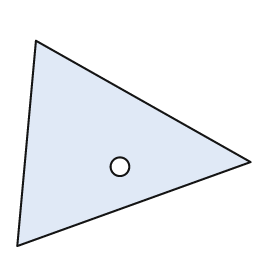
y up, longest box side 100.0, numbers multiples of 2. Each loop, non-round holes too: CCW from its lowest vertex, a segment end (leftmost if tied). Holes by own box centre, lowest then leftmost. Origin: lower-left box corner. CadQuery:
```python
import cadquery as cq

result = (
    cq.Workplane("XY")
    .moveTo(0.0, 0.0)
    .lineTo(100.0, 36.0)
    .lineTo(8.0, 88.0)
    .close()
    .moveTo(44.0, 34.0)
    .circle(4.0)
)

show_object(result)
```